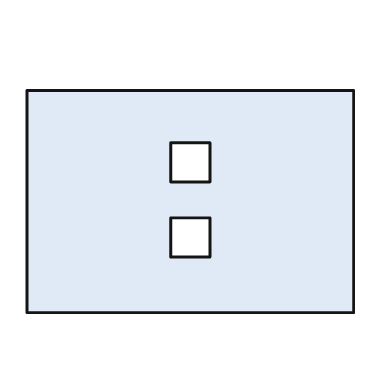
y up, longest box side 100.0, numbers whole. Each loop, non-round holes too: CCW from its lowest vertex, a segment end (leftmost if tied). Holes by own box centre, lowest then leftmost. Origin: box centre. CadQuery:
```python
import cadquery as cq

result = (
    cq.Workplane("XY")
    .moveTo(-50.0, -34.0)
    .lineTo(50.0, -34.0)
    .lineTo(50.0, 34.0)
    .lineTo(-50.0, 34.0)
    .close()
    .moveTo(-6.0, -17.0)
    .lineTo(6.0, -17.0)
    .lineTo(6.0, -5.0)
    .lineTo(-6.0, -5.0)
    .close()
    .moveTo(-6.0, 6.0)
    .lineTo(6.0, 6.0)
    .lineTo(6.0, 18.0)
    .lineTo(-6.0, 18.0)
    .close()
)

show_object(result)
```